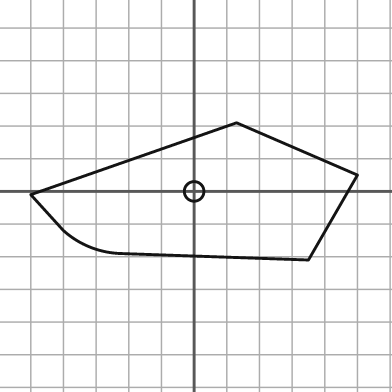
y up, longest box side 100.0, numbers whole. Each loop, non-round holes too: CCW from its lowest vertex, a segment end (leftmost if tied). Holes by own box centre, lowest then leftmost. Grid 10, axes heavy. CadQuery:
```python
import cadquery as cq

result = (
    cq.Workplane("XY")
    .moveTo(35.0, -21.0)
    .lineTo(50.0, 5.0)
    .lineTo(13.0, 21.0)
    .lineTo(-50.0, -1.0)
    .lineTo(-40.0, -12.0)
    .threePointArc((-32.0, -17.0), (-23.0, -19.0))
    .close()
    .moveTo(0.0, 0.0)
    .circle(3.0)
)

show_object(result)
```